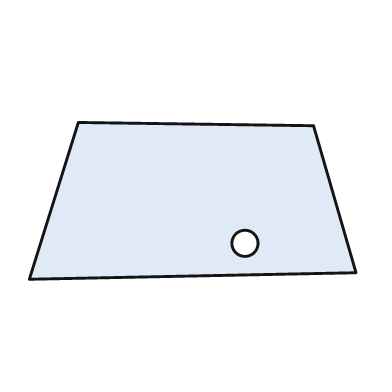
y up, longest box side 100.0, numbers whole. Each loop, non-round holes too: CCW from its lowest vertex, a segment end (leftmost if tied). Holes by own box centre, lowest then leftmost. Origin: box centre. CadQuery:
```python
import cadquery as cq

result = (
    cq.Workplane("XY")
    .moveTo(-50.0, -24.0)
    .lineTo(50.0, -22.0)
    .lineTo(37.0, 23.0)
    .lineTo(-35.0, 24.0)
    .close()
    .moveTo(16.0, -13.0)
    .circle(4.0)
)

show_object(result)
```